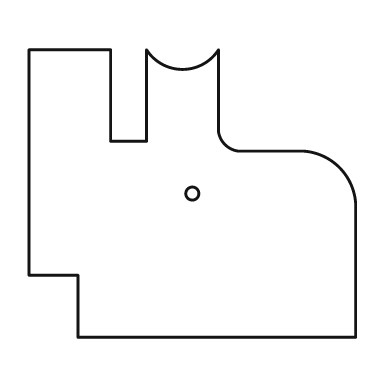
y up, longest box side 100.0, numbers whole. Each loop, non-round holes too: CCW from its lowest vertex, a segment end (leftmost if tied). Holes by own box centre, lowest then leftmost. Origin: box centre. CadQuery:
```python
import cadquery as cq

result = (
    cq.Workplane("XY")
    .moveTo(-35.0, -44.0)
    .lineTo(50.0, -44.0)
    .lineTo(50.0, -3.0)
    .threePointArc((45.0, 8.0), (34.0, 13.0))
    .lineTo(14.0, 13.0)
    .threePointArc((10.0, 15.0), (8.0, 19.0))
    .lineTo(8.0, 44.0)
    .threePointArc((-3.0, 38.0), (-14.0, 44.0))
    .lineTo(-14.0, 16.0)
    .lineTo(-25.0, 16.0)
    .lineTo(-25.0, 44.0)
    .lineTo(-50.0, 44.0)
    .lineTo(-50.0, -25.0)
    .lineTo(-35.0, -25.0)
    .close()
    .moveTo(0.0, 0.0)
    .circle(2.0)
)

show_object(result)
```